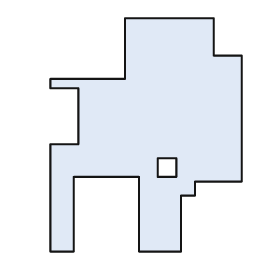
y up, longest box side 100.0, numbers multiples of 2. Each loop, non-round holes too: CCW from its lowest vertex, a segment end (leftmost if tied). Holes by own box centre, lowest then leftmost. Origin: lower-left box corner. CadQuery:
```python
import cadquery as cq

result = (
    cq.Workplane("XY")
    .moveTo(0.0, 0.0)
    .lineTo(10.0, 0.0)
    .lineTo(10.0, 32.0)
    .lineTo(38.0, 32.0)
    .lineTo(38.0, 0.0)
    .lineTo(56.0, 0.0)
    .lineTo(56.0, 24.0)
    .lineTo(62.0, 24.0)
    .lineTo(62.0, 30.0)
    .lineTo(82.0, 30.0)
    .lineTo(82.0, 84.0)
    .lineTo(70.0, 84.0)
    .lineTo(70.0, 100.0)
    .lineTo(32.0, 100.0)
    .lineTo(32.0, 74.0)
    .lineTo(0.0, 74.0)
    .lineTo(0.0, 70.0)
    .lineTo(12.0, 70.0)
    .lineTo(12.0, 46.0)
    .lineTo(0.0, 46.0)
    .close()
    .moveTo(46.0, 32.0)
    .lineTo(54.0, 32.0)
    .lineTo(54.0, 40.0)
    .lineTo(46.0, 40.0)
    .close()
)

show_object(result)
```